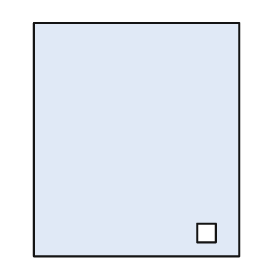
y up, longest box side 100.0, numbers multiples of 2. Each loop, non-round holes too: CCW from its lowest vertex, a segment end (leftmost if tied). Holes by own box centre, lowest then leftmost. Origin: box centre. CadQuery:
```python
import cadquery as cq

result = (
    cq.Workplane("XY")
    .moveTo(-44.0, -50.0)
    .lineTo(44.0, -50.0)
    .lineTo(44.0, 50.0)
    .lineTo(-44.0, 50.0)
    .close()
    .moveTo(26.0, -44.0)
    .lineTo(34.0, -44.0)
    .lineTo(34.0, -36.0)
    .lineTo(26.0, -36.0)
    .close()
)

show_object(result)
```